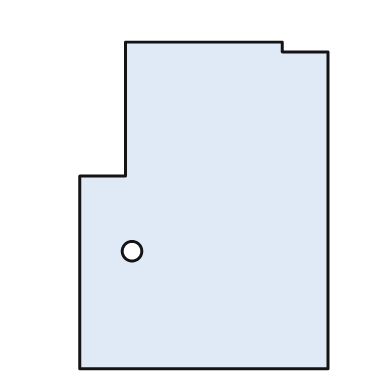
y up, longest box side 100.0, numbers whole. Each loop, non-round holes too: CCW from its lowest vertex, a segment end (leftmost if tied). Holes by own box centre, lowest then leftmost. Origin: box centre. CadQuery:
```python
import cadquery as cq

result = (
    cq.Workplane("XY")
    .moveTo(-38.0, -50.0)
    .lineTo(38.0, -50.0)
    .lineTo(38.0, 47.0)
    .lineTo(24.0, 47.0)
    .lineTo(24.0, 50.0)
    .lineTo(-24.0, 50.0)
    .lineTo(-24.0, 9.0)
    .lineTo(-38.0, 9.0)
    .close()
    .moveTo(-22.0, -14.0)
    .circle(3.0)
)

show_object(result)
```